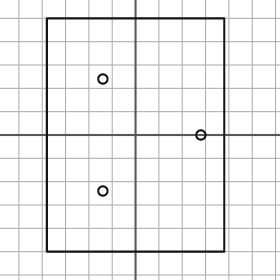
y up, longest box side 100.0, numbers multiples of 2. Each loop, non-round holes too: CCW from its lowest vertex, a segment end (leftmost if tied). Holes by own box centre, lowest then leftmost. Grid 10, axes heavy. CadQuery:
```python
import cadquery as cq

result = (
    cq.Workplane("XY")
    .moveTo(-38.0, -50.0)
    .lineTo(38.0, -50.0)
    .lineTo(38.0, 50.0)
    .lineTo(-38.0, 50.0)
    .close()
    .moveTo(-14.0, -24.0)
    .circle(2.0)
    .moveTo(28.0, 0.0)
    .circle(2.0)
    .moveTo(-14.0, 24.0)
    .circle(2.0)
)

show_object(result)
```